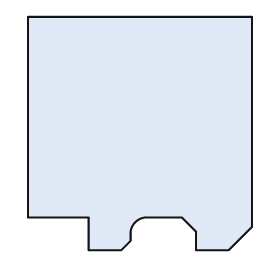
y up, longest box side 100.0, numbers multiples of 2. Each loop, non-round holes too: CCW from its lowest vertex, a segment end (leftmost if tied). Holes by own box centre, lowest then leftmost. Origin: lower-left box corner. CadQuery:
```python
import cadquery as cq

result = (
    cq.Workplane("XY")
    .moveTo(26.0, 0.0)
    .lineTo(40.0, 0.0)
    .lineTo(44.0, 4.0)
    .lineTo(44.0, 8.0)
    .threePointArc((46.0, 12.0), (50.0, 14.0))
    .lineTo(66.0, 14.0)
    .lineTo(72.0, 8.0)
    .lineTo(72.0, 0.0)
    .lineTo(86.0, 0.0)
    .lineTo(96.0, 10.0)
    .lineTo(96.0, 100.0)
    .lineTo(0.0, 100.0)
    .lineTo(0.0, 14.0)
    .lineTo(26.0, 14.0)
    .close()
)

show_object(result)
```